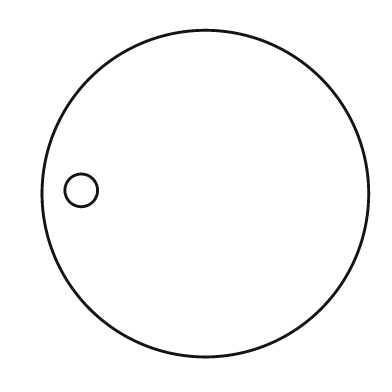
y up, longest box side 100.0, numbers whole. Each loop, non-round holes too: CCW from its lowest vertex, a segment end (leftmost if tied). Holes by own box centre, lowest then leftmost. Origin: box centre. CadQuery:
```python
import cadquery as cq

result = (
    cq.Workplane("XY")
    .moveTo(0.0, 0.0)
    .circle(50.0)
    .moveTo(-38.0, 1.0)
    .circle(5.0)
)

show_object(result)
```